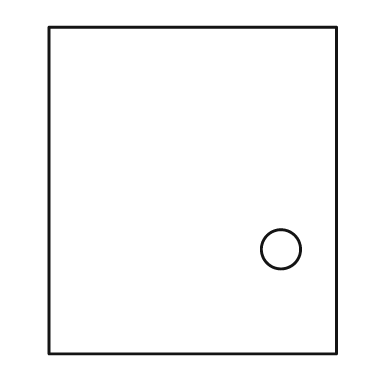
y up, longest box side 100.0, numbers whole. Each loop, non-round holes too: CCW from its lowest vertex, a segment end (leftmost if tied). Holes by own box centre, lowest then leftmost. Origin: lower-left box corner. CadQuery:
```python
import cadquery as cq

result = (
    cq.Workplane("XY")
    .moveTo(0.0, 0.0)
    .lineTo(88.0, 0.0)
    .lineTo(88.0, 100.0)
    .lineTo(0.0, 100.0)
    .close()
    .moveTo(71.0, 32.0)
    .circle(6.0)
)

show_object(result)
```